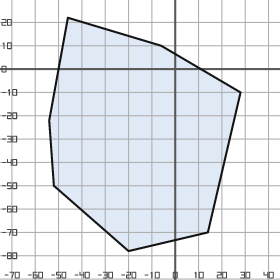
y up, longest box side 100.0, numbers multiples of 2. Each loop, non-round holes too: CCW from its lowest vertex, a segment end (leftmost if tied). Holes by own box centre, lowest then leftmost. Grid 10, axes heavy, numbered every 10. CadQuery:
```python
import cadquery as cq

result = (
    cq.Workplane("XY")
    .moveTo(-20.0, -78.0)
    .lineTo(14.0, -70.0)
    .lineTo(28.0, -10.0)
    .lineTo(-6.0, 10.0)
    .lineTo(-46.0, 22.0)
    .lineTo(-54.0, -22.0)
    .lineTo(-52.0, -50.0)
    .close()
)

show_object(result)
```